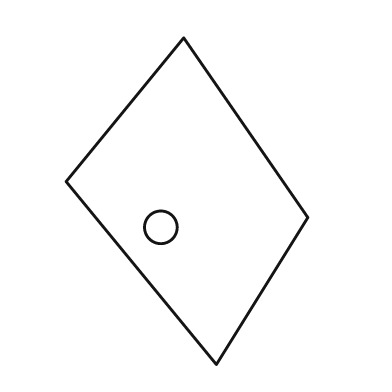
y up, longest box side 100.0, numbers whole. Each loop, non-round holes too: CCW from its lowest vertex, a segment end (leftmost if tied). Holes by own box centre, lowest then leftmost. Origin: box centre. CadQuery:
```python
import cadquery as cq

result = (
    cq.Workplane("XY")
    .moveTo(9.0, -50.0)
    .lineTo(37.0, -5.0)
    .lineTo(-1.0, 50.0)
    .lineTo(-37.0, 6.0)
    .close()
    .moveTo(-8.0, -8.0)
    .circle(5.0)
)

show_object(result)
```